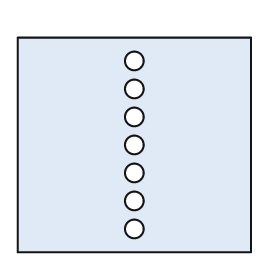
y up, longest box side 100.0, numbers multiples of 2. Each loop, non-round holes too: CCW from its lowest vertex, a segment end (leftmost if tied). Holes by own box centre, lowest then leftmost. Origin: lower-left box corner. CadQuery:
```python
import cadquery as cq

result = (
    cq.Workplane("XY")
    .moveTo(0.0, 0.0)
    .lineTo(100.0, 0.0)
    .lineTo(100.0, 92.0)
    .lineTo(0.0, 92.0)
    .close()
    .moveTo(50.0, 10.0)
    .circle(4.0)
    .moveTo(50.0, 22.0)
    .circle(4.0)
    .moveTo(50.0, 34.0)
    .circle(4.0)
    .moveTo(50.0, 46.0)
    .circle(4.0)
    .moveTo(50.0, 58.0)
    .circle(4.0)
    .moveTo(50.0, 70.0)
    .circle(4.0)
    .moveTo(50.0, 82.0)
    .circle(4.0)
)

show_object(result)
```